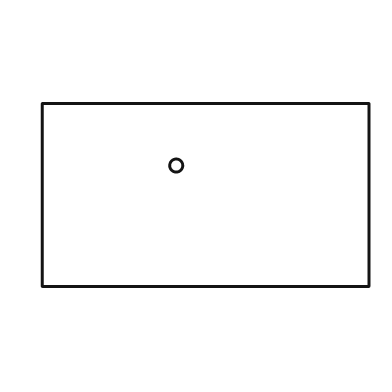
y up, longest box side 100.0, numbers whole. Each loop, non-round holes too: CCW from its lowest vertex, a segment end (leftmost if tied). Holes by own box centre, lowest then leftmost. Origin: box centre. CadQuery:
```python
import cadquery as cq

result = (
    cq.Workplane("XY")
    .moveTo(-50.0, -28.0)
    .lineTo(50.0, -28.0)
    .lineTo(50.0, 28.0)
    .lineTo(-50.0, 28.0)
    .close()
    .moveTo(-9.0, 9.0)
    .circle(2.0)
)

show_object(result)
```